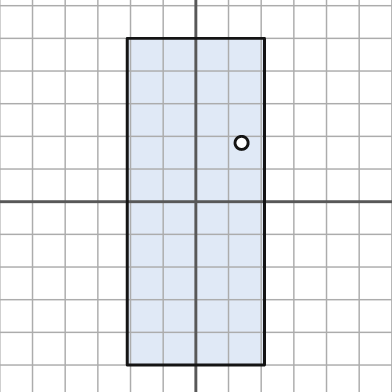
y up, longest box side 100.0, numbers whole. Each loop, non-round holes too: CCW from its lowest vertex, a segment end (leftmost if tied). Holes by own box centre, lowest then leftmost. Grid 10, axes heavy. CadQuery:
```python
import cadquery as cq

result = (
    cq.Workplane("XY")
    .moveTo(-21.0, -50.0)
    .lineTo(21.0, -50.0)
    .lineTo(21.0, 50.0)
    .lineTo(-21.0, 50.0)
    .close()
    .moveTo(14.0, 18.0)
    .circle(2.0)
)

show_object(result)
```